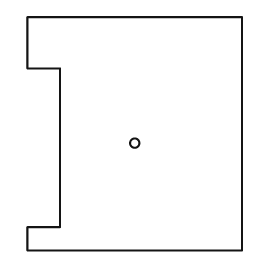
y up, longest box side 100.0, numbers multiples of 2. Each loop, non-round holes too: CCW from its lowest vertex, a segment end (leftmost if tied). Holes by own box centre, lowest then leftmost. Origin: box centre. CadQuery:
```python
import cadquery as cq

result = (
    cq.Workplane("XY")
    .moveTo(-46.0, -50.0)
    .lineTo(46.0, -50.0)
    .lineTo(46.0, 50.0)
    .lineTo(-46.0, 50.0)
    .lineTo(-46.0, 28.0)
    .lineTo(-32.0, 28.0)
    .lineTo(-32.0, -40.0)
    .lineTo(-46.0, -40.0)
    .close()
    .moveTo(0.0, -4.0)
    .circle(2.0)
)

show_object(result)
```